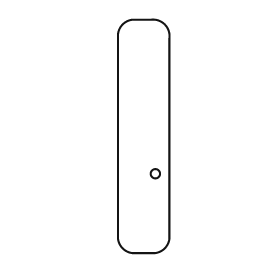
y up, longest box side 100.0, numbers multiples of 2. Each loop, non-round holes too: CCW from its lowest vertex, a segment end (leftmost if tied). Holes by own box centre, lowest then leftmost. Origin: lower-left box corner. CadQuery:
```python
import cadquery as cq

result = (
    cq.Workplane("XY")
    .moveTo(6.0, 0.0)
    .lineTo(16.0, 0.0)
    .threePointArc((20.0, 2.0), (22.0, 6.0))
    .lineTo(22.0, 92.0)
    .threePointArc((20.0, 98.0), (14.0, 100.0))
    .lineTo(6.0, 100.0)
    .threePointArc((2.0, 98.0), (0.0, 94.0))
    .lineTo(0.0, 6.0)
    .threePointArc((2.0, 2.0), (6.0, 0.0))
    .close()
    .moveTo(16.0, 34.0)
    .circle(2.0)
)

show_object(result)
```